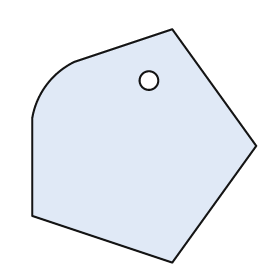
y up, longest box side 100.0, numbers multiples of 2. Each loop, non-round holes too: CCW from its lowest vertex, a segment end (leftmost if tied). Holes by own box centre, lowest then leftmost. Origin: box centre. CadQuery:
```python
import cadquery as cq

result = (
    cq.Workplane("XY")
    .moveTo(12.0, -50.0)
    .lineTo(48.0, 0.0)
    .lineTo(12.0, 50.0)
    .lineTo(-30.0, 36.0)
    .threePointArc((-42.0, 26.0), (-48.0, 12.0))
    .lineTo(-48.0, -30.0)
    .close()
    .moveTo(2.0, 28.0)
    .circle(4.0)
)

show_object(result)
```